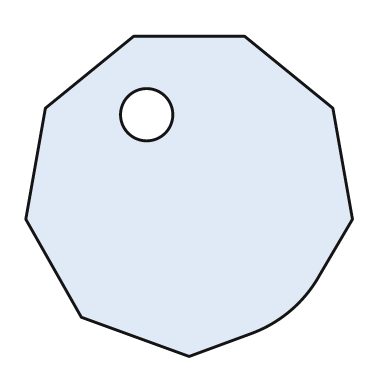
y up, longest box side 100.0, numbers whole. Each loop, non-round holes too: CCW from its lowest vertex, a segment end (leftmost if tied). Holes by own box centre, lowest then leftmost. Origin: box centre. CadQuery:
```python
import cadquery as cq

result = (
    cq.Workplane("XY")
    .moveTo(0.0, -49.0)
    .lineTo(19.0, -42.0)
    .threePointArc((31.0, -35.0), (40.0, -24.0))
    .lineTo(50.0, -7.0)
    .lineTo(44.0, 27.0)
    .lineTo(17.0, 49.0)
    .lineTo(-17.0, 49.0)
    .lineTo(-44.0, 27.0)
    .lineTo(-50.0, -7.0)
    .lineTo(-33.0, -37.0)
    .close()
    .moveTo(-13.0, 25.0)
    .circle(8.0)
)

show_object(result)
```